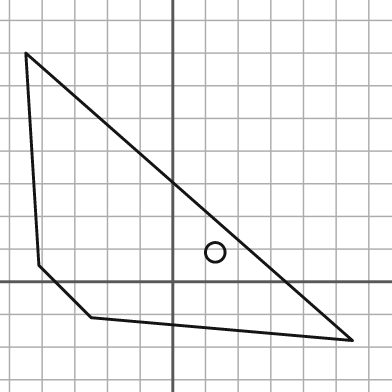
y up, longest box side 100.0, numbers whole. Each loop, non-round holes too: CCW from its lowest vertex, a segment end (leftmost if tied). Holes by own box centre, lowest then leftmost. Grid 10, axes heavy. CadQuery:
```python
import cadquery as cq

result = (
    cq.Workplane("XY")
    .moveTo(55.0, -18.0)
    .lineTo(-45.0, 70.0)
    .lineTo(-41.0, 5.0)
    .lineTo(-25.0, -11.0)
    .close()
    .moveTo(13.0, 9.0)
    .circle(3.0)
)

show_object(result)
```